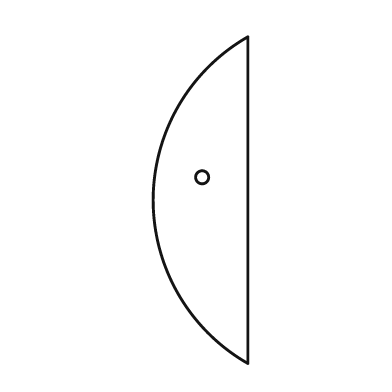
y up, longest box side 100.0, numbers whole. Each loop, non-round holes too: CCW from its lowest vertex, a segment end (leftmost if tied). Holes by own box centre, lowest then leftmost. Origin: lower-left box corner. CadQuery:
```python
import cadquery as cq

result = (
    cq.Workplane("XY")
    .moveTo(29.0, 0.0)
    .lineTo(29.0, 100.0)
    .threePointArc((0.0, 50.0), (29.0, 0.0))
    .close()
    .moveTo(15.0, 57.0)
    .circle(2.0)
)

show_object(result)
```